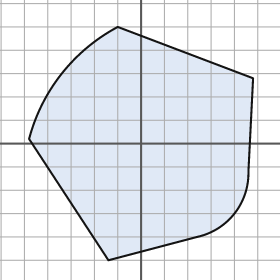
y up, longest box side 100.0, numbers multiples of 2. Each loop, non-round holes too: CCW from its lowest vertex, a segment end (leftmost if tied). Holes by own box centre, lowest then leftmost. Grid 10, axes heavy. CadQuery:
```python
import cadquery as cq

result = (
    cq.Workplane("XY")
    .moveTo(-14.0, -50.0)
    .lineTo(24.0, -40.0)
    .threePointArc((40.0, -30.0), (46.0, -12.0))
    .lineTo(48.0, 28.0)
    .lineTo(-10.0, 50.0)
    .threePointArc((-34.0, 30.0), (-48.0, 2.0))
    .close()
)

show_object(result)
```